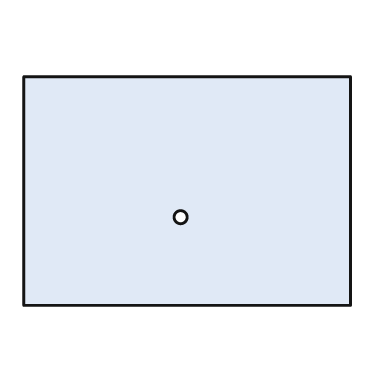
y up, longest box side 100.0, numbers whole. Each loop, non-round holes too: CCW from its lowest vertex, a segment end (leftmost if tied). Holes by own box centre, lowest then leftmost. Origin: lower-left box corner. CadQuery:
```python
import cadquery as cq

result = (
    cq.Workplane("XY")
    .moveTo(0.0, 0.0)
    .lineTo(100.0, 0.0)
    .lineTo(100.0, 70.0)
    .lineTo(0.0, 70.0)
    .close()
    .moveTo(48.0, 27.0)
    .circle(2.0)
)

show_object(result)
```